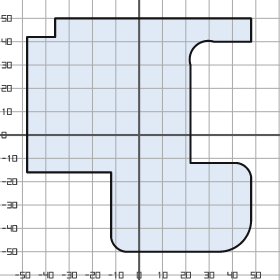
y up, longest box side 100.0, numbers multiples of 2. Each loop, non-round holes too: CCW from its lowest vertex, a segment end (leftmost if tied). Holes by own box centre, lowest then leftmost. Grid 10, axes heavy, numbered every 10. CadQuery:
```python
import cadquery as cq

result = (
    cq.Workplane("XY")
    .moveTo(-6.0, -50.0)
    .lineTo(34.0, -50.0)
    .threePointArc((44.0, -46.0), (48.0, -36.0))
    .lineTo(48.0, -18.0)
    .threePointArc((46.0, -14.0), (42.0, -12.0))
    .lineTo(22.0, -12.0)
    .lineTo(22.0, 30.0)
    .threePointArc((24.0, 38.0), (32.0, 40.0))
    .lineTo(48.0, 40.0)
    .lineTo(48.0, 50.0)
    .lineTo(-36.0, 50.0)
    .lineTo(-36.0, 42.0)
    .lineTo(-48.0, 42.0)
    .lineTo(-48.0, -16.0)
    .lineTo(-12.0, -16.0)
    .lineTo(-12.0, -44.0)
    .threePointArc((-10.0, -48.0), (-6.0, -50.0))
    .close()
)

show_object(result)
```